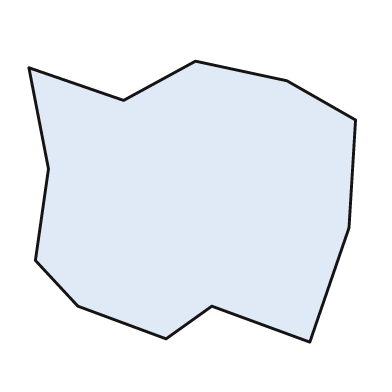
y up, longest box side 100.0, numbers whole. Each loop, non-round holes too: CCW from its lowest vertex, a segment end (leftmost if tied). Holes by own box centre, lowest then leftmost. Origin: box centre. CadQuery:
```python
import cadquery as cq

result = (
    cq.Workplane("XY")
    .moveTo(36.0, -43.0)
    .lineTo(48.0, -8.0)
    .lineTo(50.0, 25.0)
    .lineTo(29.0, 37.0)
    .lineTo(1.0, 43.0)
    .lineTo(-21.0, 31.0)
    .lineTo(-50.0, 41.0)
    .lineTo(-44.0, 10.0)
    .lineTo(-48.0, -18.0)
    .lineTo(-35.0, -32.0)
    .lineTo(-8.0, -42.0)
    .lineTo(6.0, -32.0)
    .close()
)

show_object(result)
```